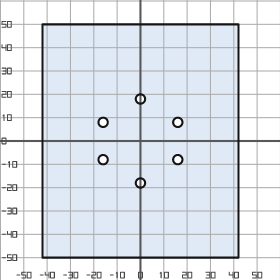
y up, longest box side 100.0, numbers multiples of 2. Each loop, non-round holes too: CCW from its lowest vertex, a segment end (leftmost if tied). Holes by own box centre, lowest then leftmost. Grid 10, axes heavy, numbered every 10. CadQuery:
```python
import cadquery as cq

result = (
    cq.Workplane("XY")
    .moveTo(-42.0, -50.0)
    .lineTo(42.0, -50.0)
    .lineTo(42.0, 50.0)
    .lineTo(-42.0, 50.0)
    .close()
    .moveTo(0.0, -18.0)
    .circle(2.0)
    .moveTo(-16.0, -8.0)
    .circle(2.0)
    .moveTo(16.0, -8.0)
    .circle(2.0)
    .moveTo(-16.0, 8.0)
    .circle(2.0)
    .moveTo(16.0, 8.0)
    .circle(2.0)
    .moveTo(0.0, 18.0)
    .circle(2.0)
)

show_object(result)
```